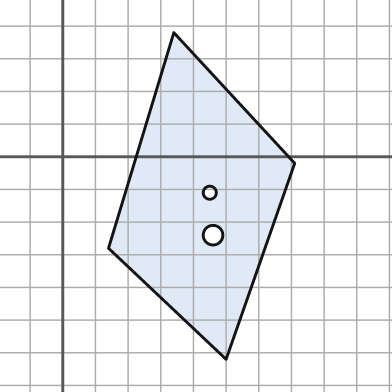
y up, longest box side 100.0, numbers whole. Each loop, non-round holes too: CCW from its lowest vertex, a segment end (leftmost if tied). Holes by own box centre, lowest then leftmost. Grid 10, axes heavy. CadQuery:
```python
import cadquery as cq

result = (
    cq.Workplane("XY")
    .moveTo(50.0, -62.0)
    .lineTo(71.0, -2.0)
    .lineTo(34.0, 38.0)
    .lineTo(14.0, -28.0)
    .close()
    .moveTo(46.0, -24.0)
    .circle(3.0)
    .moveTo(45.0, -11.0)
    .circle(2.0)
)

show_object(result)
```